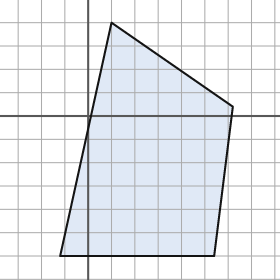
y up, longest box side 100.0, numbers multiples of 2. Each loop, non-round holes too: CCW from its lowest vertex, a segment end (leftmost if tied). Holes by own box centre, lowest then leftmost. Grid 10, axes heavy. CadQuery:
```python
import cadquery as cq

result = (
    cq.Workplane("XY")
    .moveTo(-12.0, -60.0)
    .lineTo(54.0, -60.0)
    .lineTo(62.0, 4.0)
    .lineTo(10.0, 40.0)
    .close()
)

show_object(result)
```